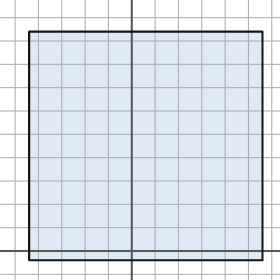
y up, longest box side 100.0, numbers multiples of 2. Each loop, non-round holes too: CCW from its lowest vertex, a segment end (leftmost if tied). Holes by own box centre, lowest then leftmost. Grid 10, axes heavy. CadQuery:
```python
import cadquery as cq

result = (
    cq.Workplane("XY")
    .moveTo(-44.0, -4.0)
    .lineTo(56.0, -4.0)
    .lineTo(56.0, 94.0)
    .lineTo(-44.0, 94.0)
    .close()
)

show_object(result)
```